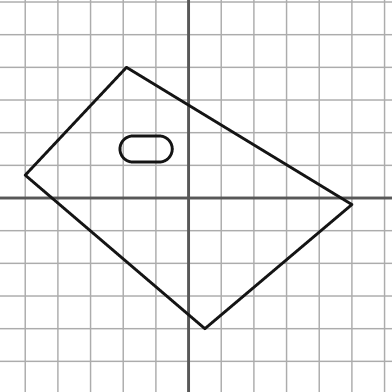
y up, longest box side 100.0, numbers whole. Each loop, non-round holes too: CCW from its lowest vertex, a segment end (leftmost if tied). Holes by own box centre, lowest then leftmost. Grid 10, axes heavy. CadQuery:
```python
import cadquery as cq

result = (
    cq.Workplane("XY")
    .moveTo(5.0, -40.0)
    .lineTo(50.0, -2.0)
    .lineTo(-19.0, 40.0)
    .lineTo(-50.0, 7.0)
    .close()
    .moveTo(-17.0, 11.0)
    .lineTo(-9.0, 11.0)
    .threePointArc((-5.0, 15.0), (-9.0, 19.0))
    .lineTo(-17.0, 19.0)
    .threePointArc((-21.0, 15.0), (-17.0, 11.0))
    .close()
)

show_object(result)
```